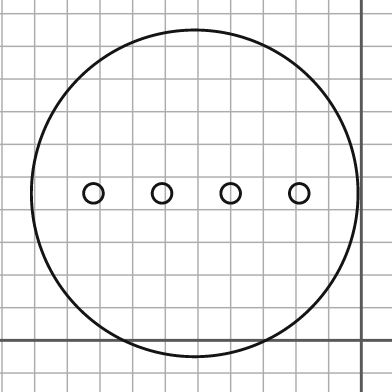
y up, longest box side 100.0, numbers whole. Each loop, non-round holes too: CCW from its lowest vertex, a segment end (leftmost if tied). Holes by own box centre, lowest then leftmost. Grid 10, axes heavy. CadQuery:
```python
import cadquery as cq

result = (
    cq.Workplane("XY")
    .moveTo(-51.0, 45.0)
    .circle(50.0)
    .moveTo(-82.0, 45.0)
    .circle(3.0)
    .moveTo(-61.0, 45.0)
    .circle(3.0)
    .moveTo(-40.0, 45.0)
    .circle(3.0)
    .moveTo(-19.0, 45.0)
    .circle(3.0)
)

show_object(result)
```